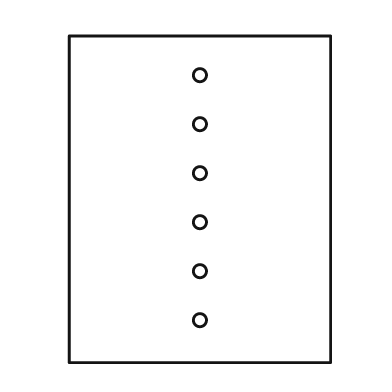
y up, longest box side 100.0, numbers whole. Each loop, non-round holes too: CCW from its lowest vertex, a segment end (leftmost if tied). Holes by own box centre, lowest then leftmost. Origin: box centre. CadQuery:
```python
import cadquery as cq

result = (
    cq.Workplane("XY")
    .moveTo(-40.0, -50.0)
    .lineTo(40.0, -50.0)
    .lineTo(40.0, 50.0)
    .lineTo(-40.0, 50.0)
    .close()
    .moveTo(0.0, -37.0)
    .circle(2.0)
    .moveTo(0.0, -22.0)
    .circle(2.0)
    .moveTo(0.0, -7.0)
    .circle(2.0)
    .moveTo(0.0, 8.0)
    .circle(2.0)
    .moveTo(0.0, 23.0)
    .circle(2.0)
    .moveTo(0.0, 38.0)
    .circle(2.0)
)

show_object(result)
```